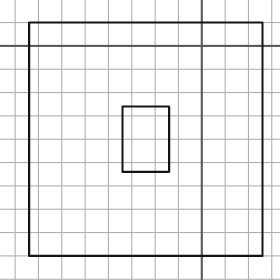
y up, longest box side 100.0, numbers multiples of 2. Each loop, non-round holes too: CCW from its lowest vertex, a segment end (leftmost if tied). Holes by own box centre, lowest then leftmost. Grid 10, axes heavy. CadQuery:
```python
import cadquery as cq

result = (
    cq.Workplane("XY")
    .moveTo(-74.0, -90.0)
    .lineTo(26.0, -90.0)
    .lineTo(26.0, 10.0)
    .lineTo(-74.0, 10.0)
    .close()
    .moveTo(-34.0, -54.0)
    .lineTo(-14.0, -54.0)
    .lineTo(-14.0, -26.0)
    .lineTo(-34.0, -26.0)
    .close()
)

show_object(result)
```